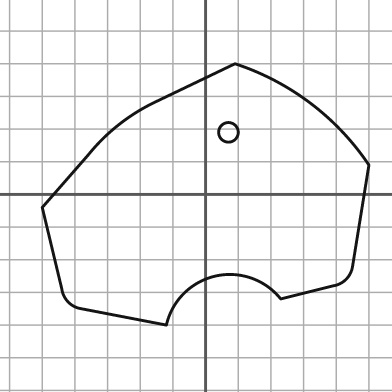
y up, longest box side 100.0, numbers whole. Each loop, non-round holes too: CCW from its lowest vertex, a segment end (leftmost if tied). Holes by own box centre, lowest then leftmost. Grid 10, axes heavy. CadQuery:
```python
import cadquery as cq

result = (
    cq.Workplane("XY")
    .moveTo(-12.0, -40.0)
    .threePointArc((3.0, -25.0), (23.0, -32.0))
    .lineTo(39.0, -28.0)
    .threePointArc((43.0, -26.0), (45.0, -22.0))
    .lineTo(50.0, 9.0)
    .threePointArc((32.0, 28.0), (9.0, 40.0))
    .lineTo(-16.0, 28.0)
    .threePointArc((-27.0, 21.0), (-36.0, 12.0))
    .lineTo(-50.0, -4.0)
    .lineTo(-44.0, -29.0)
    .threePointArc((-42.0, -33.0), (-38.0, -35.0))
    .close()
    .moveTo(7.0, 19.0)
    .circle(3.0)
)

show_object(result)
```